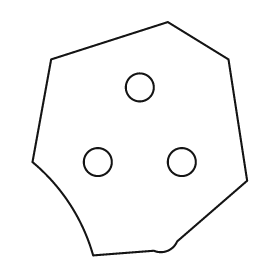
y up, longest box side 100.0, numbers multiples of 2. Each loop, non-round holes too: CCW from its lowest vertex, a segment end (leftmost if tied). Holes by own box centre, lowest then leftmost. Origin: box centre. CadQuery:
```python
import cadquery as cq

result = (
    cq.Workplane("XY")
    .moveTo(-20.0, -50.0)
    .lineTo(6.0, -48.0)
    .threePointArc((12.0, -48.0), (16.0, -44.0))
    .lineTo(46.0, -18.0)
    .lineTo(38.0, 34.0)
    .lineTo(12.0, 50.0)
    .lineTo(-38.0, 34.0)
    .lineTo(-46.0, -10.0)
    .threePointArc((-30.0, -28.0), (-20.0, -50.0))
    .close()
    .moveTo(-18.0, -10.0)
    .circle(6.0)
    .moveTo(18.0, -10.0)
    .circle(6.0)
    .moveTo(0.0, 22.0)
    .circle(6.0)
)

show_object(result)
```